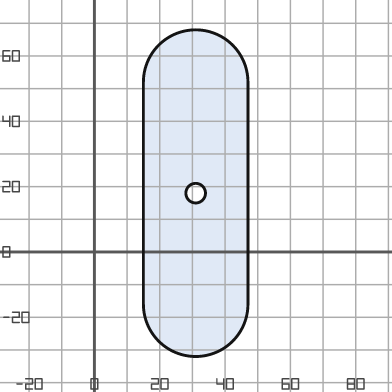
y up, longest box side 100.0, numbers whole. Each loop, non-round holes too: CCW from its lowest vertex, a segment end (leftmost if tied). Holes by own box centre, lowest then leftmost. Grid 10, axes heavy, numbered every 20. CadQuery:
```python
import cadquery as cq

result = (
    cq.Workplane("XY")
    .moveTo(15.0, -16.0)
    .threePointArc((31.0, -32.0), (47.0, -16.0))
    .lineTo(47.0, 52.0)
    .threePointArc((31.0, 68.0), (15.0, 52.0))
    .close()
    .moveTo(31.0, 18.0)
    .circle(3.0)
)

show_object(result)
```